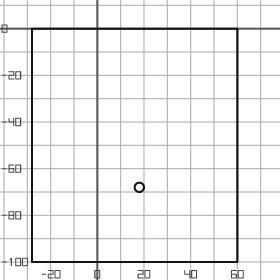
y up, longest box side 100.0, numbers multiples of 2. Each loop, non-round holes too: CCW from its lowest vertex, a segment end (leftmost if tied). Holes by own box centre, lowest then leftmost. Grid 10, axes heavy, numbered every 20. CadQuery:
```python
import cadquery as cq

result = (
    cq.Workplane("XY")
    .moveTo(-28.0, -100.0)
    .lineTo(60.0, -100.0)
    .lineTo(60.0, 0.0)
    .lineTo(-28.0, 0.0)
    .close()
    .moveTo(18.0, -68.0)
    .circle(2.0)
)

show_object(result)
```